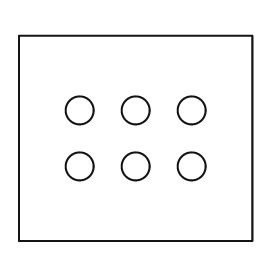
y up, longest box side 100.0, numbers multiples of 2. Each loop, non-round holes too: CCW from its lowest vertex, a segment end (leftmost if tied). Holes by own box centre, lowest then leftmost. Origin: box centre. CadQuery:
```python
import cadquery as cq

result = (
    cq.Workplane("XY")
    .moveTo(-50.0, -44.0)
    .lineTo(50.0, -44.0)
    .lineTo(50.0, 44.0)
    .lineTo(-50.0, 44.0)
    .close()
    .moveTo(-24.0, -12.0)
    .circle(6.0)
    .moveTo(0.0, -12.0)
    .circle(6.0)
    .moveTo(24.0, -12.0)
    .circle(6.0)
    .moveTo(-24.0, 12.0)
    .circle(6.0)
    .moveTo(0.0, 12.0)
    .circle(6.0)
    .moveTo(24.0, 12.0)
    .circle(6.0)
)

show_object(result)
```